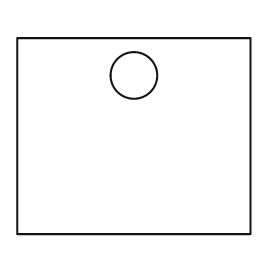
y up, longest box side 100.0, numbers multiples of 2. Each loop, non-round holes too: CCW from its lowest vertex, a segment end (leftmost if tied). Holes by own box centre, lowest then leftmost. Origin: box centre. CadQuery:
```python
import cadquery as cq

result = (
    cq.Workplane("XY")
    .moveTo(-50.0, -42.0)
    .lineTo(50.0, -42.0)
    .lineTo(50.0, 42.0)
    .lineTo(-50.0, 42.0)
    .close()
    .moveTo(0.0, 26.0)
    .circle(10.0)
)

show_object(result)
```